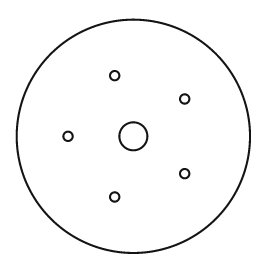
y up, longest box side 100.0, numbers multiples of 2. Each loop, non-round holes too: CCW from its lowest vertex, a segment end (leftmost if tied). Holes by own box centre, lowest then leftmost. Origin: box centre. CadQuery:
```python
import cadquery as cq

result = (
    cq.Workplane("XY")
    .moveTo(0.0, 0.0)
    .circle(50.0)
    .moveTo(-8.0, -26.0)
    .circle(2.0)
    .moveTo(22.0, -16.0)
    .circle(2.0)
    .moveTo(-28.0, 0.0)
    .circle(2.0)
    .moveTo(0.0, 0.0)
    .circle(6.0)
    .moveTo(22.0, 16.0)
    .circle(2.0)
    .moveTo(-8.0, 26.0)
    .circle(2.0)
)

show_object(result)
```